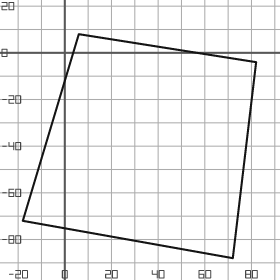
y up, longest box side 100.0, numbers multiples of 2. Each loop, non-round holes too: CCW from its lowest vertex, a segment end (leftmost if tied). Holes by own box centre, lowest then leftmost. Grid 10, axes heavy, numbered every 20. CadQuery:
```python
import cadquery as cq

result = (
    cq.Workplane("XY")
    .moveTo(72.0, -88.0)
    .lineTo(82.0, -4.0)
    .lineTo(6.0, 8.0)
    .lineTo(-18.0, -72.0)
    .close()
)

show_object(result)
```